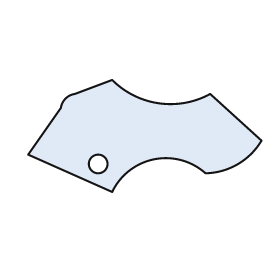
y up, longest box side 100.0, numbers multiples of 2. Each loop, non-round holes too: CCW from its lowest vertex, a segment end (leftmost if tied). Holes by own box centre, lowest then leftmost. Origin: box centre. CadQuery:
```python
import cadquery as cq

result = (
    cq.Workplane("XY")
    .moveTo(-14.0, -24.0)
    .threePointArc((4.0, -10.0), (26.0, -16.0))
    .threePointArc((40.0, -12.0), (50.0, -2.0))
    .lineTo(28.0, 18.0)
    .threePointArc((6.0, 14.0), (-14.0, 24.0))
    .lineTo(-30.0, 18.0)
    .threePointArc((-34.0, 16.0), (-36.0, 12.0))
    .lineTo(-50.0, -8.0)
    .close()
    .moveTo(-20.0, -12.0)
    .circle(4.0)
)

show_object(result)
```